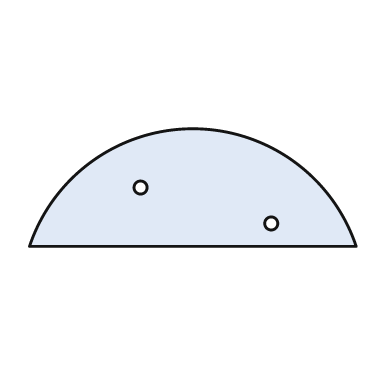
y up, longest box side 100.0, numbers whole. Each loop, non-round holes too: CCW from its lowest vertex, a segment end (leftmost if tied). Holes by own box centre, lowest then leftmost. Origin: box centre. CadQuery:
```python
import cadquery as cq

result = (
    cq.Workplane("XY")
    .moveTo(-50.0, -18.0)
    .lineTo(50.0, -18.0)
    .threePointArc((0.0, 18.0), (-50.0, -18.0))
    .close()
    .moveTo(24.0, -11.0)
    .circle(2.0)
    .moveTo(-16.0, 0.0)
    .circle(2.0)
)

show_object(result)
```